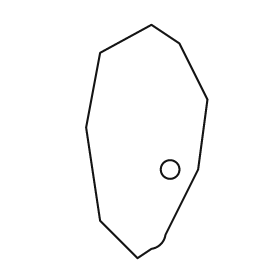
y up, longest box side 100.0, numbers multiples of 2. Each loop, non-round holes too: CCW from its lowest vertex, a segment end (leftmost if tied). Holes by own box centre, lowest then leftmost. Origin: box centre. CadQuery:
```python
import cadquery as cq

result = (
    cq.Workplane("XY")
    .moveTo(-4.0, -50.0)
    .lineTo(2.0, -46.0)
    .threePointArc((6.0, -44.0), (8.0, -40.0))
    .lineTo(22.0, -12.0)
    .lineTo(26.0, 18.0)
    .lineTo(14.0, 42.0)
    .lineTo(2.0, 50.0)
    .lineTo(-20.0, 38.0)
    .lineTo(-26.0, 6.0)
    .lineTo(-20.0, -34.0)
    .close()
    .moveTo(10.0, -12.0)
    .circle(4.0)
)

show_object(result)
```